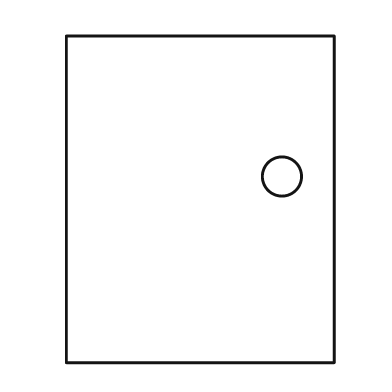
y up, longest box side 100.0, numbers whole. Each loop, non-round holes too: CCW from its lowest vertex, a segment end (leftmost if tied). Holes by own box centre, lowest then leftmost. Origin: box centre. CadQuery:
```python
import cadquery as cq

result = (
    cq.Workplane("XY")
    .moveTo(-41.0, -50.0)
    .lineTo(41.0, -50.0)
    .lineTo(41.0, 50.0)
    .lineTo(-41.0, 50.0)
    .close()
    .moveTo(25.0, 7.0)
    .circle(6.0)
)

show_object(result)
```